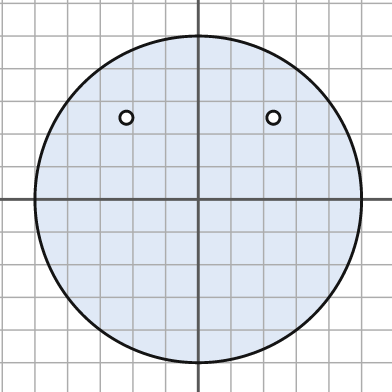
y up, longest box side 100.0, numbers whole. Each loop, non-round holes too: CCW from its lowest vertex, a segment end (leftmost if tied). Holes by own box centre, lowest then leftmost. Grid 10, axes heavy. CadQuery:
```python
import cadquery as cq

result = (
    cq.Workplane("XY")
    .moveTo(0.0, 0.0)
    .circle(50.0)
    .moveTo(-22.0, 25.0)
    .circle(2.0)
    .moveTo(23.0, 25.0)
    .circle(2.0)
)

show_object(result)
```